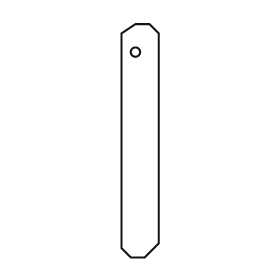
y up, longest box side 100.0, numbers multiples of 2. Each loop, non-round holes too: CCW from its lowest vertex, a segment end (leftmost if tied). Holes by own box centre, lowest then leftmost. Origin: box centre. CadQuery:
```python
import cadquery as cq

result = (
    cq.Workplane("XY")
    .moveTo(-4.0, -50.0)
    .lineTo(2.0, -50.0)
    .lineTo(8.0, -44.0)
    .lineTo(8.0, 46.0)
    .lineTo(4.0, 50.0)
    .lineTo(-2.0, 50.0)
    .lineTo(-8.0, 46.0)
    .lineTo(-8.0, -46.0)
    .close()
    .moveTo(-2.0, 38.0)
    .circle(2.0)
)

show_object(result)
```